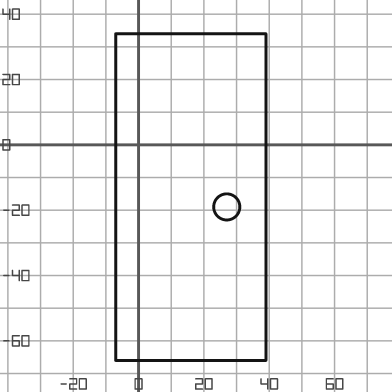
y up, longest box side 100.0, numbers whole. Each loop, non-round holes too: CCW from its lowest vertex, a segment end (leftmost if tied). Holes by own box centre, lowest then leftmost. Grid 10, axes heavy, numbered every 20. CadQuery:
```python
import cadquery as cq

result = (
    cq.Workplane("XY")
    .moveTo(-7.0, -66.0)
    .lineTo(39.0, -66.0)
    .lineTo(39.0, 34.0)
    .lineTo(-7.0, 34.0)
    .close()
    .moveTo(27.0, -19.0)
    .circle(4.0)
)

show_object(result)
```